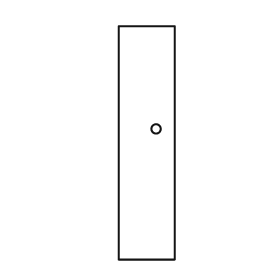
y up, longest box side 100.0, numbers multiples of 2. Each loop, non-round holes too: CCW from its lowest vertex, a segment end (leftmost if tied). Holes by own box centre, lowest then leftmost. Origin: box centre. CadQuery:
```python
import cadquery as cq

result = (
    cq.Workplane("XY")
    .moveTo(-12.0, -50.0)
    .lineTo(12.0, -50.0)
    .lineTo(12.0, 50.0)
    .lineTo(-12.0, 50.0)
    .close()
    .moveTo(4.0, 6.0)
    .circle(2.0)
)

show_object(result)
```